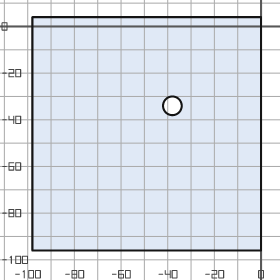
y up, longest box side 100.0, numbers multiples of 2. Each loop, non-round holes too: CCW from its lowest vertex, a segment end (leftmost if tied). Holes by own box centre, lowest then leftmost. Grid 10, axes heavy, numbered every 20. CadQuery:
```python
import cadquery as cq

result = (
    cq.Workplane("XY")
    .moveTo(-98.0, -96.0)
    .lineTo(0.0, -96.0)
    .lineTo(0.0, 4.0)
    .lineTo(-98.0, 4.0)
    .close()
    .moveTo(-38.0, -34.0)
    .circle(4.0)
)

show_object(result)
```